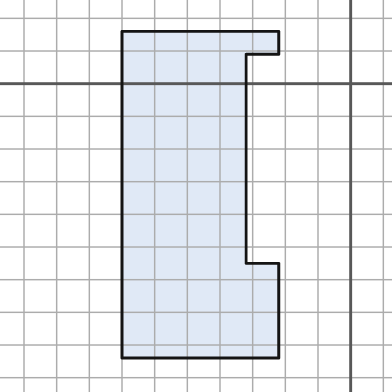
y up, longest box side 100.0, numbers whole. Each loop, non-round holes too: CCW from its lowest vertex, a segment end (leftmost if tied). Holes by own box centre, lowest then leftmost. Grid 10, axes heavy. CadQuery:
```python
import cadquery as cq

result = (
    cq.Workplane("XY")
    .moveTo(-70.0, -84.0)
    .lineTo(-22.0, -84.0)
    .lineTo(-22.0, -55.0)
    .lineTo(-32.0, -55.0)
    .lineTo(-32.0, 9.0)
    .lineTo(-22.0, 9.0)
    .lineTo(-22.0, 16.0)
    .lineTo(-70.0, 16.0)
    .close()
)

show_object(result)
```